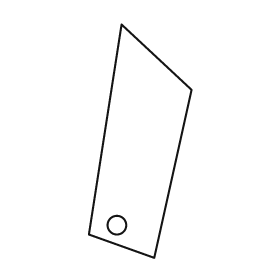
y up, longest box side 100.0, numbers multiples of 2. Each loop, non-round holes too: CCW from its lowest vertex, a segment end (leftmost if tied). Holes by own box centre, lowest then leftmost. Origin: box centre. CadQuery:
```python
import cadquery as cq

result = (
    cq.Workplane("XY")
    .moveTo(6.0, -50.0)
    .lineTo(22.0, 22.0)
    .lineTo(-8.0, 50.0)
    .lineTo(-22.0, -40.0)
    .close()
    .moveTo(-10.0, -36.0)
    .circle(4.0)
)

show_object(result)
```